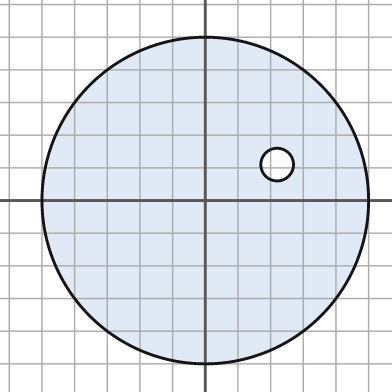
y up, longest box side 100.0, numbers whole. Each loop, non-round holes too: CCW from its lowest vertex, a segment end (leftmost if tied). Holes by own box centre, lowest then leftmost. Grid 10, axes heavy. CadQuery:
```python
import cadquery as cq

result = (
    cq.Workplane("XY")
    .moveTo(0.0, 0.0)
    .circle(50.0)
    .moveTo(22.0, 11.0)
    .circle(5.0)
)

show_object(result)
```